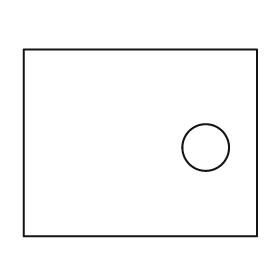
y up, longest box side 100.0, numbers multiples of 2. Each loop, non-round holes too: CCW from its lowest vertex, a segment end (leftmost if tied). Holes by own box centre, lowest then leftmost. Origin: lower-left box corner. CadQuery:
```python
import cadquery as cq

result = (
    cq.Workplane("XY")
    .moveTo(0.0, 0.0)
    .lineTo(100.0, 0.0)
    .lineTo(100.0, 80.0)
    .lineTo(0.0, 80.0)
    .close()
    .moveTo(78.0, 38.0)
    .circle(10.0)
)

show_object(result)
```